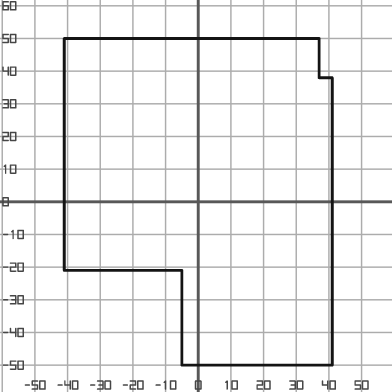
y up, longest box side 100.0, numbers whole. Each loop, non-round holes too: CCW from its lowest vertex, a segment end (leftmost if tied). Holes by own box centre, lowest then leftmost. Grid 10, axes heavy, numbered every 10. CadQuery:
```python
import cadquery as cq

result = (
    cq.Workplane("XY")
    .moveTo(-5.0, -50.0)
    .lineTo(41.0, -50.0)
    .lineTo(41.0, 38.0)
    .lineTo(37.0, 38.0)
    .lineTo(37.0, 50.0)
    .lineTo(-41.0, 50.0)
    .lineTo(-41.0, -21.0)
    .lineTo(-5.0, -21.0)
    .close()
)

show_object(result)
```